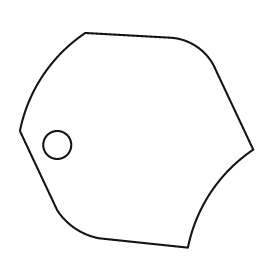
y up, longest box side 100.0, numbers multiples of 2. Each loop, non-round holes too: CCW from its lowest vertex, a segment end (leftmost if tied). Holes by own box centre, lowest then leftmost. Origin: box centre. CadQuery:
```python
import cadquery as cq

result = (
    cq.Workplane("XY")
    .moveTo(22.0, -46.0)
    .threePointArc((32.0, -22.0), (50.0, -4.0))
    .lineTo(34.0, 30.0)
    .threePointArc((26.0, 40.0), (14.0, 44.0))
    .lineTo(-22.0, 46.0)
    .threePointArc((-40.0, 28.0), (-50.0, 4.0))
    .lineTo(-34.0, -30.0)
    .threePointArc((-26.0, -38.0), (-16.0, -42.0))
    .close()
    .moveTo(-34.0, -2.0)
    .circle(6.0)
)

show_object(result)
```